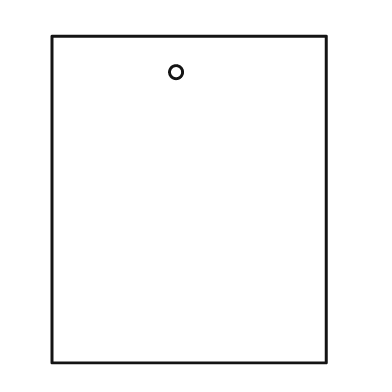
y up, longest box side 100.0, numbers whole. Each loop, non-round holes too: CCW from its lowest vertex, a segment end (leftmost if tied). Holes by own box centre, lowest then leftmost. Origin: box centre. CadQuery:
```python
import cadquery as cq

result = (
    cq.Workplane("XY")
    .moveTo(-42.0, -50.0)
    .lineTo(42.0, -50.0)
    .lineTo(42.0, 50.0)
    .lineTo(-42.0, 50.0)
    .close()
    .moveTo(-4.0, 39.0)
    .circle(2.0)
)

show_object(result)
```